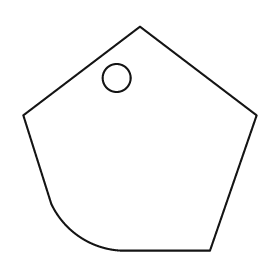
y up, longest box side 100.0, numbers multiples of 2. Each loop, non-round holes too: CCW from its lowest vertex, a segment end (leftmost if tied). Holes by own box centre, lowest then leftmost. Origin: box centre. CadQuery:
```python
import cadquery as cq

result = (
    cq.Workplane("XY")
    .moveTo(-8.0, -48.0)
    .lineTo(30.0, -48.0)
    .lineTo(50.0, 10.0)
    .lineTo(0.0, 48.0)
    .lineTo(-50.0, 10.0)
    .lineTo(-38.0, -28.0)
    .threePointArc((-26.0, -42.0), (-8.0, -48.0))
    .close()
    .moveTo(-10.0, 26.0)
    .circle(6.0)
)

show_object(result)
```